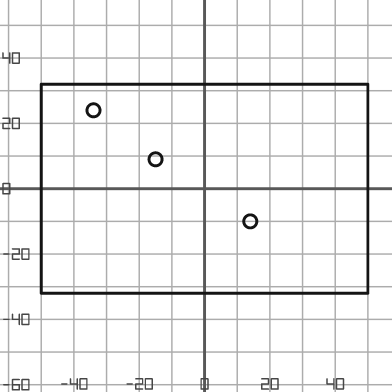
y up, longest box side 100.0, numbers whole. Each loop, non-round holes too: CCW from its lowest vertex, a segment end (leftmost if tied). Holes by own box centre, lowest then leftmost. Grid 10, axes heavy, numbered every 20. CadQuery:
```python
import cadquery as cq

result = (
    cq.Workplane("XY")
    .moveTo(-50.0, -32.0)
    .lineTo(50.0, -32.0)
    .lineTo(50.0, 32.0)
    .lineTo(-50.0, 32.0)
    .close()
    .moveTo(14.0, -10.0)
    .circle(2.0)
    .moveTo(-15.0, 9.0)
    .circle(2.0)
    .moveTo(-34.0, 24.0)
    .circle(2.0)
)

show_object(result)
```